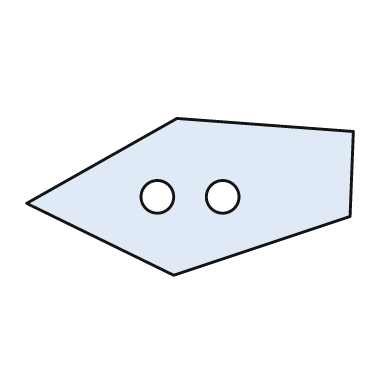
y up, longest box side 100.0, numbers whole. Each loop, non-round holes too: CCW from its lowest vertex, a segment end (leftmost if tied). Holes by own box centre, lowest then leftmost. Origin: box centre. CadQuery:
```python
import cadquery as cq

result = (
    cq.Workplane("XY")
    .moveTo(-5.0, -24.0)
    .lineTo(49.0, -6.0)
    .lineTo(50.0, 20.0)
    .lineTo(-4.0, 24.0)
    .lineTo(-50.0, -2.0)
    .close()
    .moveTo(-10.0, 0.0)
    .circle(5.0)
    .moveTo(10.0, 0.0)
    .circle(5.0)
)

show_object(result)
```